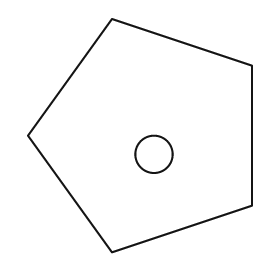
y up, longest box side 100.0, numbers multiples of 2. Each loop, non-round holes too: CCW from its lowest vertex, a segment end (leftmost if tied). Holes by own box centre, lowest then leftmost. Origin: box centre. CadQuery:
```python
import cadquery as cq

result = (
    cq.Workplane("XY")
    .moveTo(-12.0, -50.0)
    .lineTo(48.0, -30.0)
    .lineTo(48.0, 30.0)
    .lineTo(-12.0, 50.0)
    .lineTo(-48.0, 0.0)
    .close()
    .moveTo(6.0, -8.0)
    .circle(8.0)
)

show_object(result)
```